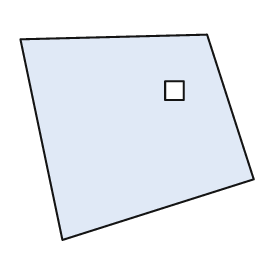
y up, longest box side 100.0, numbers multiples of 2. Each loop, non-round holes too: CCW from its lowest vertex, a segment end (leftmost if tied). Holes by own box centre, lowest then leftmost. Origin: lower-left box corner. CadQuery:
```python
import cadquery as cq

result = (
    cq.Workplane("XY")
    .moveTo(18.0, 0.0)
    .lineTo(100.0, 26.0)
    .lineTo(80.0, 88.0)
    .lineTo(0.0, 86.0)
    .close()
    .moveTo(62.0, 60.0)
    .lineTo(70.0, 60.0)
    .lineTo(70.0, 68.0)
    .lineTo(62.0, 68.0)
    .close()
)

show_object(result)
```